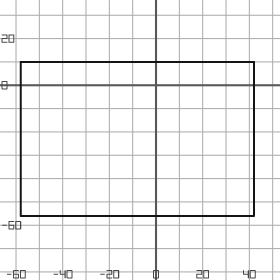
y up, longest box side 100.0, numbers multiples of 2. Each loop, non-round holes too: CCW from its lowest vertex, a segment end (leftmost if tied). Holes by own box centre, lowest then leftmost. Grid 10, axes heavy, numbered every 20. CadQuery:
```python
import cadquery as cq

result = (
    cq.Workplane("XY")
    .moveTo(-58.0, -56.0)
    .lineTo(42.0, -56.0)
    .lineTo(42.0, 10.0)
    .lineTo(-58.0, 10.0)
    .close()
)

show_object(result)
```